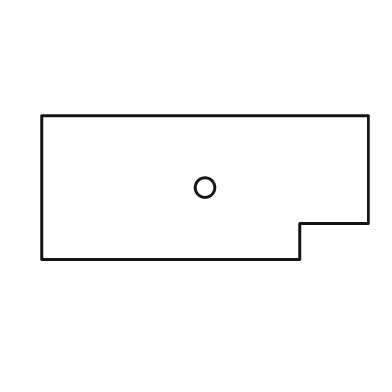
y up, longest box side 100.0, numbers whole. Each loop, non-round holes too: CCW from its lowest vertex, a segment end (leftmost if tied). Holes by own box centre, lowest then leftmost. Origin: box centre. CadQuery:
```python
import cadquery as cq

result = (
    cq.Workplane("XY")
    .moveTo(-50.0, -22.0)
    .lineTo(29.0, -22.0)
    .lineTo(29.0, -11.0)
    .lineTo(50.0, -11.0)
    .lineTo(50.0, 22.0)
    .lineTo(-50.0, 22.0)
    .close()
    .moveTo(0.0, 0.0)
    .circle(3.0)
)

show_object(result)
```